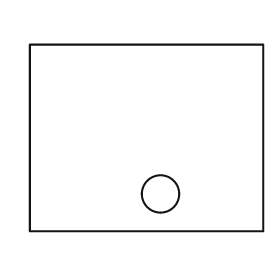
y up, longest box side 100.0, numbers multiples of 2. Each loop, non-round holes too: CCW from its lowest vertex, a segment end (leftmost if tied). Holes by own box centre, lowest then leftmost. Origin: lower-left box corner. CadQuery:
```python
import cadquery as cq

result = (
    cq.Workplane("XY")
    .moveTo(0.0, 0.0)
    .lineTo(100.0, 0.0)
    .lineTo(100.0, 80.0)
    .lineTo(0.0, 80.0)
    .close()
    .moveTo(56.0, 16.0)
    .circle(8.0)
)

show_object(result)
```